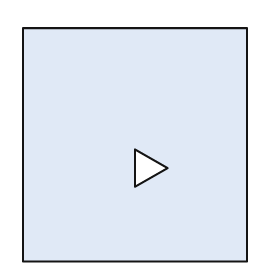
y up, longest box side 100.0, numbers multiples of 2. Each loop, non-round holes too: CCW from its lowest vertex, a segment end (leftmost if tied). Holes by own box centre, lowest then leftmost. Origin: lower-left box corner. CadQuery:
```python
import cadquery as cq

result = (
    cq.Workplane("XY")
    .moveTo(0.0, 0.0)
    .lineTo(96.0, 0.0)
    .lineTo(96.0, 100.0)
    .lineTo(0.0, 100.0)
    .close()
    .moveTo(48.0, 32.0)
    .lineTo(62.0, 40.0)
    .lineTo(48.0, 48.0)
    .close()
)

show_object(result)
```